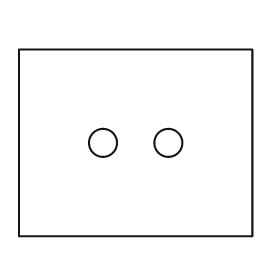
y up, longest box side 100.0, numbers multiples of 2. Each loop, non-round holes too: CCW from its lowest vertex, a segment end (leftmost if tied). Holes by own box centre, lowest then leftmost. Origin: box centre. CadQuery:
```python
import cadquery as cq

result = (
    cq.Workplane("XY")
    .moveTo(-50.0, -40.0)
    .lineTo(50.0, -40.0)
    .lineTo(50.0, 40.0)
    .lineTo(-50.0, 40.0)
    .close()
    .moveTo(-14.0, 0.0)
    .circle(6.0)
    .moveTo(14.0, 0.0)
    .circle(6.0)
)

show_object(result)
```